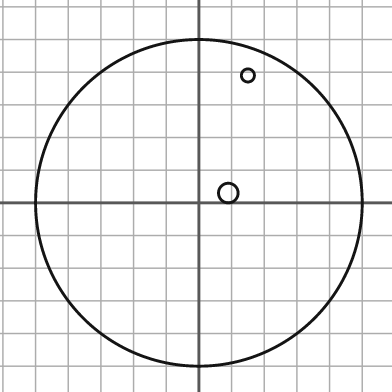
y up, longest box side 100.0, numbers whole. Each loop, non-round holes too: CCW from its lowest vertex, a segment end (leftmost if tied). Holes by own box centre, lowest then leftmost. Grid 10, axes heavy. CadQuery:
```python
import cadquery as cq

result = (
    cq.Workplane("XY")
    .moveTo(0.0, 0.0)
    .circle(50.0)
    .moveTo(9.0, 3.0)
    .circle(3.0)
    .moveTo(15.0, 39.0)
    .circle(2.0)
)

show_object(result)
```